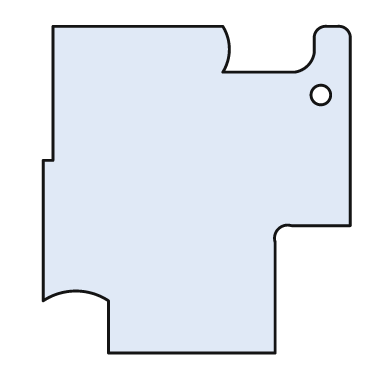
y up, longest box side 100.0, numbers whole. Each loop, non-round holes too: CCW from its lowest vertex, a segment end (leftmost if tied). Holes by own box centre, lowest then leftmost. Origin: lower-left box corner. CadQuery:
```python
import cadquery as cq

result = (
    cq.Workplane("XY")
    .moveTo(20.0, 0.0)
    .lineTo(71.0, 0.0)
    .lineTo(71.0, 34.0)
    .threePointArc((72.0, 38.0), (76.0, 39.0))
    .lineTo(94.0, 39.0)
    .lineTo(94.0, 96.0)
    .threePointArc((93.0, 99.0), (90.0, 100.0))
    .lineTo(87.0, 100.0)
    .threePointArc((84.0, 99.0), (83.0, 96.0))
    .lineTo(83.0, 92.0)
    .threePointArc((81.0, 88.0), (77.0, 86.0))
    .lineTo(55.0, 86.0)
    .threePointArc((57.0, 93.0), (55.0, 100.0))
    .lineTo(3.0, 100.0)
    .lineTo(3.0, 59.0)
    .lineTo(0.0, 59.0)
    .lineTo(0.0, 16.0)
    .threePointArc((10.0, 19.0), (20.0, 16.0))
    .close()
    .moveTo(85.0, 79.0)
    .circle(3.0)
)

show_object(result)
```